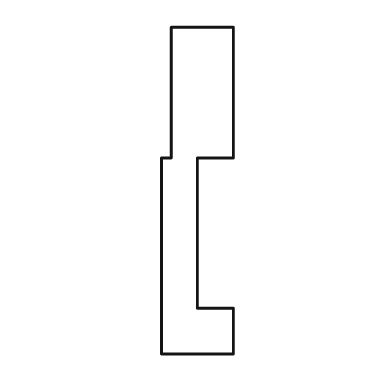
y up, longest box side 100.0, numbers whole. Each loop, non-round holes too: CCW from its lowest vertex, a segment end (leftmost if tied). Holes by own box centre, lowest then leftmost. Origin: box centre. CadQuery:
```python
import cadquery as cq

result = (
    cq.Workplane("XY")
    .moveTo(-11.0, -50.0)
    .lineTo(11.0, -50.0)
    .lineTo(11.0, -36.0)
    .lineTo(0.0, -36.0)
    .lineTo(0.0, 10.0)
    .lineTo(11.0, 10.0)
    .lineTo(11.0, 50.0)
    .lineTo(-8.0, 50.0)
    .lineTo(-8.0, 10.0)
    .lineTo(-11.0, 10.0)
    .close()
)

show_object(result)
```